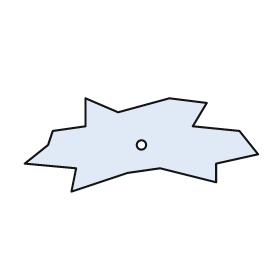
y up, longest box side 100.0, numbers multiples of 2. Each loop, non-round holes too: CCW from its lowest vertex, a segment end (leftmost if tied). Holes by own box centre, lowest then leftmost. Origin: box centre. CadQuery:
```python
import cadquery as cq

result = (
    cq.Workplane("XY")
    .moveTo(-30.0, -20.0)
    .lineTo(-6.0, -12.0)
    .lineTo(8.0, -10.0)
    .lineTo(32.0, -16.0)
    .lineTo(32.0, -8.0)
    .lineTo(50.0, -4.0)
    .lineTo(42.0, 6.0)
    .lineTo(22.0, 8.0)
    .lineTo(28.0, 18.0)
    .lineTo(12.0, 20.0)
    .lineTo(-10.0, 14.0)
    .lineTo(-24.0, 20.0)
    .lineTo(-24.0, 8.0)
    .lineTo(-38.0, 6.0)
    .lineTo(-40.0, 0.0)
    .lineTo(-50.0, -8.0)
    .lineTo(-28.0, -10.0)
    .close()
    .moveTo(0.0, 0.0)
    .circle(2.0)
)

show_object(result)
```